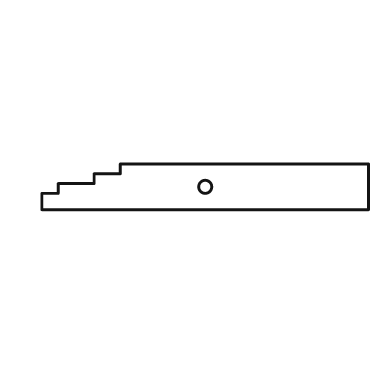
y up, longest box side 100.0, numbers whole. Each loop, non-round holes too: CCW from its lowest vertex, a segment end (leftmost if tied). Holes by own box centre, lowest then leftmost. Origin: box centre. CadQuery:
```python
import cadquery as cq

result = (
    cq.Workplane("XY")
    .moveTo(-50.0, -7.0)
    .lineTo(50.0, -7.0)
    .lineTo(50.0, 7.0)
    .lineTo(-26.0, 7.0)
    .lineTo(-26.0, 4.0)
    .lineTo(-34.0, 4.0)
    .lineTo(-34.0, 1.0)
    .lineTo(-45.0, 1.0)
    .lineTo(-45.0, -2.0)
    .lineTo(-50.0, -2.0)
    .close()
    .moveTo(0.0, 0.0)
    .circle(2.0)
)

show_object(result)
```